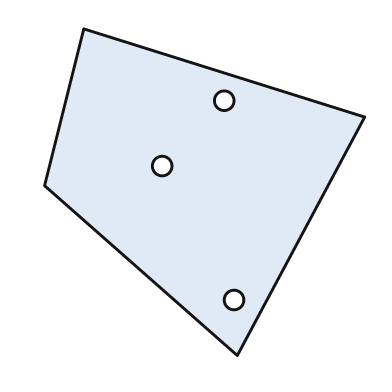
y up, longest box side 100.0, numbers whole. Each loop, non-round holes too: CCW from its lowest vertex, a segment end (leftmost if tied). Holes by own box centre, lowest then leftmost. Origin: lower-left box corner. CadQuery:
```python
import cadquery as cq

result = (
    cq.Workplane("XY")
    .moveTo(59.0, 0.0)
    .lineTo(98.0, 73.0)
    .lineTo(12.0, 100.0)
    .lineTo(0.0, 52.0)
    .close()
    .moveTo(58.0, 17.0)
    .circle(3.0)
    .moveTo(36.0, 58.0)
    .circle(3.0)
    .moveTo(55.0, 78.0)
    .circle(3.0)
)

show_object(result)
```